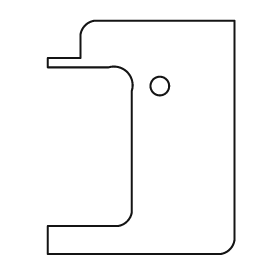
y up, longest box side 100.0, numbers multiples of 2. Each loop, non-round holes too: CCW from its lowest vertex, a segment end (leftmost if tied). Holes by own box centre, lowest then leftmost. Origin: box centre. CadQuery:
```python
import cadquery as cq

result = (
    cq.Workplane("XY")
    .moveTo(-40.0, -50.0)
    .lineTo(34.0, -50.0)
    .threePointArc((38.0, -48.0), (40.0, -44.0))
    .lineTo(40.0, 50.0)
    .lineTo(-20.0, 50.0)
    .threePointArc((-24.0, 48.0), (-26.0, 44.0))
    .lineTo(-26.0, 34.0)
    .lineTo(-40.0, 34.0)
    .lineTo(-40.0, 30.0)
    .lineTo(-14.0, 30.0)
    .threePointArc((-6.0, 28.0), (-4.0, 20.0))
    .lineTo(-4.0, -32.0)
    .threePointArc((-6.0, -36.0), (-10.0, -38.0))
    .lineTo(-40.0, -38.0)
    .close()
    .moveTo(8.0, 22.0)
    .circle(4.0)
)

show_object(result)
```